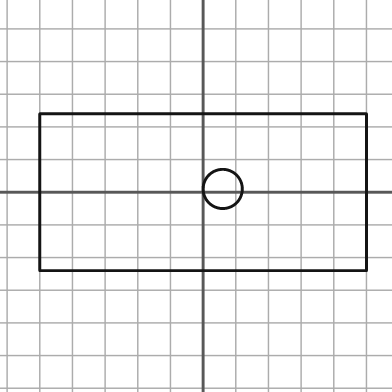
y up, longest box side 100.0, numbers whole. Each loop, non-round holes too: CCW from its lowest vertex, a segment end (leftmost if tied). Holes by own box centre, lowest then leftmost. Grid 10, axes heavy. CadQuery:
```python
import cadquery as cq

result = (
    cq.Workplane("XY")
    .moveTo(-50.0, -24.0)
    .lineTo(50.0, -24.0)
    .lineTo(50.0, 24.0)
    .lineTo(-50.0, 24.0)
    .close()
    .moveTo(6.0, 1.0)
    .circle(6.0)
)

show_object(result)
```